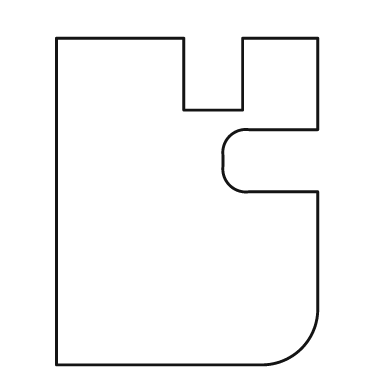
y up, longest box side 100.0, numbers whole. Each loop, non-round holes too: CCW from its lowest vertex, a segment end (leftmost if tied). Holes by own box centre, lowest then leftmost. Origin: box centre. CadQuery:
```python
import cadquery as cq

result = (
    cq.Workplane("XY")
    .moveTo(-40.0, -50.0)
    .lineTo(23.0, -50.0)
    .threePointArc((35.0, -45.0), (40.0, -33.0))
    .lineTo(40.0, 3.0)
    .lineTo(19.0, 3.0)
    .threePointArc((13.0, 5.0), (11.0, 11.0))
    .lineTo(11.0, 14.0)
    .threePointArc((13.0, 20.0), (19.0, 22.0))
    .lineTo(40.0, 22.0)
    .lineTo(40.0, 50.0)
    .lineTo(17.0, 50.0)
    .lineTo(17.0, 28.0)
    .lineTo(-1.0, 28.0)
    .lineTo(-1.0, 50.0)
    .lineTo(-40.0, 50.0)
    .close()
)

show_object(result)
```